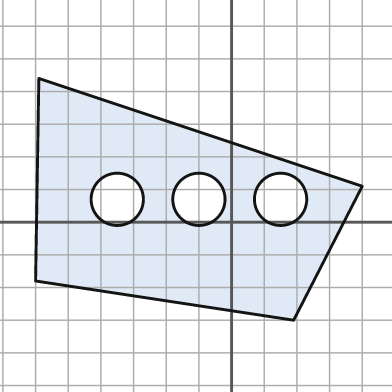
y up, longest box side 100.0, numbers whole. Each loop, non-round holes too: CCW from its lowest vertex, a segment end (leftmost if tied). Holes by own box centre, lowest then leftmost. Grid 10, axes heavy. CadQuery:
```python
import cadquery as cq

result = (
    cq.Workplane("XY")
    .moveTo(19.0, -30.0)
    .lineTo(40.0, 11.0)
    .lineTo(-59.0, 44.0)
    .lineTo(-60.0, -18.0)
    .close()
    .moveTo(-35.0, 7.0)
    .circle(8.0)
    .moveTo(-10.0, 7.0)
    .circle(8.0)
    .moveTo(15.0, 7.0)
    .circle(8.0)
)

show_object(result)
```